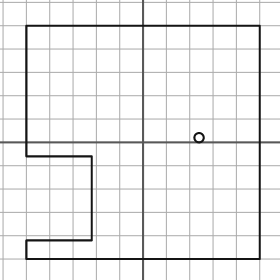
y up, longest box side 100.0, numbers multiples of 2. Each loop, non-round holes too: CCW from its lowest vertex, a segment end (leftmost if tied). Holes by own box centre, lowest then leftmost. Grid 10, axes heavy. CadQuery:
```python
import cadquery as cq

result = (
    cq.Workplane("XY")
    .moveTo(-50.0, -50.0)
    .lineTo(50.0, -50.0)
    .lineTo(50.0, 50.0)
    .lineTo(-50.0, 50.0)
    .lineTo(-50.0, -6.0)
    .lineTo(-22.0, -6.0)
    .lineTo(-22.0, -42.0)
    .lineTo(-50.0, -42.0)
    .close()
    .moveTo(24.0, 2.0)
    .circle(2.0)
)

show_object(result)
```